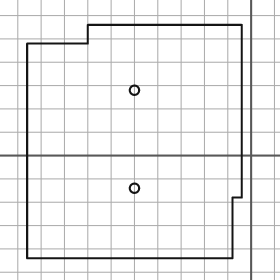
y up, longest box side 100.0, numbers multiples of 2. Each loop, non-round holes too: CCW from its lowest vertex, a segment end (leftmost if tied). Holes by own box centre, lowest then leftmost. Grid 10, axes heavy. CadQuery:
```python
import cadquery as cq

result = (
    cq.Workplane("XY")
    .moveTo(-96.0, -44.0)
    .lineTo(-8.0, -44.0)
    .lineTo(-8.0, -18.0)
    .lineTo(-4.0, -18.0)
    .lineTo(-4.0, 56.0)
    .lineTo(-70.0, 56.0)
    .lineTo(-70.0, 48.0)
    .lineTo(-96.0, 48.0)
    .close()
    .moveTo(-50.0, -14.0)
    .circle(2.0)
    .moveTo(-50.0, 28.0)
    .circle(2.0)
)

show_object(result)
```